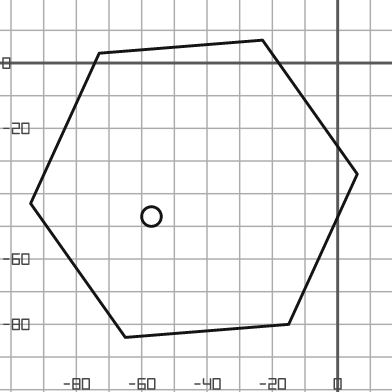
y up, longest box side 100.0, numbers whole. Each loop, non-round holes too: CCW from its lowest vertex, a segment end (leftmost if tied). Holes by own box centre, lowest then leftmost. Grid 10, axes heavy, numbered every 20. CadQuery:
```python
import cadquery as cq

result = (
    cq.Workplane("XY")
    .moveTo(-65.0, -84.0)
    .lineTo(-15.0, -80.0)
    .lineTo(6.0, -34.0)
    .lineTo(-23.0, 7.0)
    .lineTo(-73.0, 3.0)
    .lineTo(-94.0, -43.0)
    .close()
    .moveTo(-57.0, -47.0)
    .circle(3.0)
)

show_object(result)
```